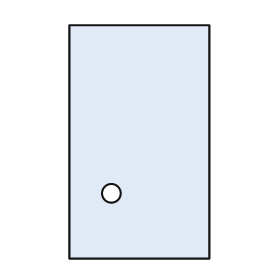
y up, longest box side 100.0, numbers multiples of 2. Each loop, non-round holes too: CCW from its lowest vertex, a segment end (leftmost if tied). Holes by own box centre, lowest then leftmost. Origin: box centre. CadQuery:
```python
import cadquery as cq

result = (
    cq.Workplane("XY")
    .moveTo(-30.0, -50.0)
    .lineTo(30.0, -50.0)
    .lineTo(30.0, 50.0)
    .lineTo(-30.0, 50.0)
    .close()
    .moveTo(-12.0, -22.0)
    .circle(4.0)
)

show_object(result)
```